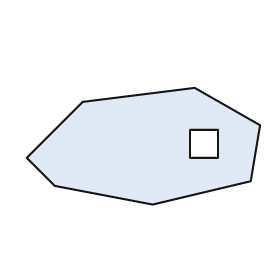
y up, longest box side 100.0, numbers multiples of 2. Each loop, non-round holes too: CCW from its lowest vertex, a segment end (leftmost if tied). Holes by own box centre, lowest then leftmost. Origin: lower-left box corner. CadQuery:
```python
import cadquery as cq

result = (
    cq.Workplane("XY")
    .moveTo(54.0, 0.0)
    .lineTo(96.0, 10.0)
    .lineTo(100.0, 34.0)
    .lineTo(72.0, 50.0)
    .lineTo(24.0, 44.0)
    .lineTo(0.0, 20.0)
    .lineTo(12.0, 8.0)
    .close()
    .moveTo(70.0, 20.0)
    .lineTo(82.0, 20.0)
    .lineTo(82.0, 32.0)
    .lineTo(70.0, 32.0)
    .close()
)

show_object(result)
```